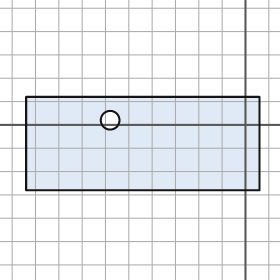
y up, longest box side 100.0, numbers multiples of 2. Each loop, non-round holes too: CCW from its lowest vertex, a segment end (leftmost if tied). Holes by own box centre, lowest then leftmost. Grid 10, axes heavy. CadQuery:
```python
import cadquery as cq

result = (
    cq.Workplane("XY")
    .moveTo(-94.0, -28.0)
    .lineTo(6.0, -28.0)
    .lineTo(6.0, 12.0)
    .lineTo(-94.0, 12.0)
    .close()
    .moveTo(-58.0, 2.0)
    .circle(4.0)
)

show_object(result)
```